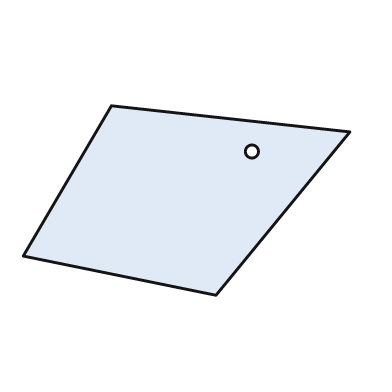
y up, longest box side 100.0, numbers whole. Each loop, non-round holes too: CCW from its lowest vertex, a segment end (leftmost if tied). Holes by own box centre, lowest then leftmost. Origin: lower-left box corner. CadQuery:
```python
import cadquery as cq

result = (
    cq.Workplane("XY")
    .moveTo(59.0, 0.0)
    .lineTo(100.0, 50.0)
    .lineTo(27.0, 58.0)
    .lineTo(0.0, 12.0)
    .close()
    .moveTo(70.0, 44.0)
    .circle(2.0)
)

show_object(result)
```